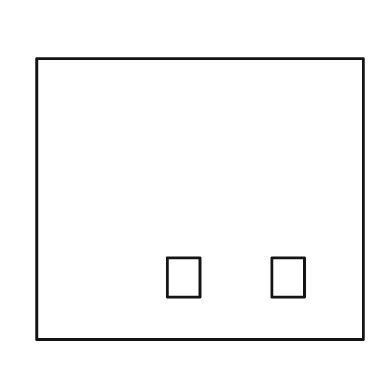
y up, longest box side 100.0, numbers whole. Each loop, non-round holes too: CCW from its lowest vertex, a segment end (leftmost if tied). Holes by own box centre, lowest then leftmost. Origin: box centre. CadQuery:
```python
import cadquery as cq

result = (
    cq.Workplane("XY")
    .moveTo(-50.0, -43.0)
    .lineTo(50.0, -43.0)
    .lineTo(50.0, 43.0)
    .lineTo(-50.0, 43.0)
    .close()
    .moveTo(-10.0, -30.0)
    .lineTo(0.0, -30.0)
    .lineTo(0.0, -18.0)
    .lineTo(-10.0, -18.0)
    .close()
    .moveTo(22.0, -30.0)
    .lineTo(32.0, -30.0)
    .lineTo(32.0, -18.0)
    .lineTo(22.0, -18.0)
    .close()
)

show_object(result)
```